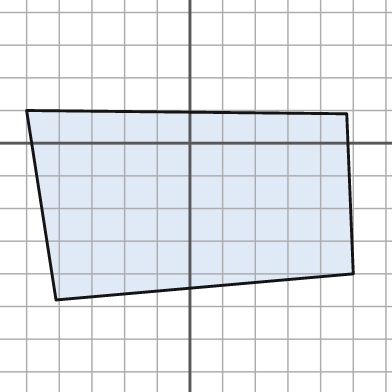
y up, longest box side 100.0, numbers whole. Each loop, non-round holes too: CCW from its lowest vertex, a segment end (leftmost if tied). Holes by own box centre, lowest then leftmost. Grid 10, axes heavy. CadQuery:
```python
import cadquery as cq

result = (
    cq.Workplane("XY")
    .moveTo(-41.0, -48.0)
    .lineTo(50.0, -40.0)
    .lineTo(48.0, 9.0)
    .lineTo(-50.0, 10.0)
    .close()
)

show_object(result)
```